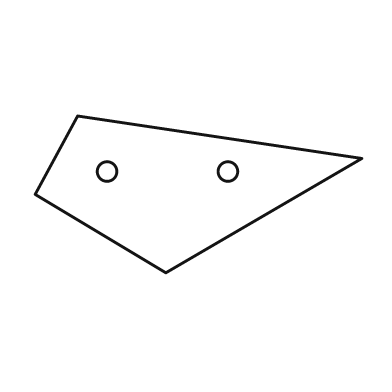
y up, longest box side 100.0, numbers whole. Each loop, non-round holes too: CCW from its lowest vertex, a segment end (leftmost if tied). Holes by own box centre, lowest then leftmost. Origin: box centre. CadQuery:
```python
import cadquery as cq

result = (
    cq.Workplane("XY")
    .moveTo(-10.0, -24.0)
    .lineTo(50.0, 11.0)
    .lineTo(-37.0, 24.0)
    .lineTo(-50.0, 0.0)
    .close()
    .moveTo(-28.0, 7.0)
    .circle(3.0)
    .moveTo(9.0, 7.0)
    .circle(3.0)
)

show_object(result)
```